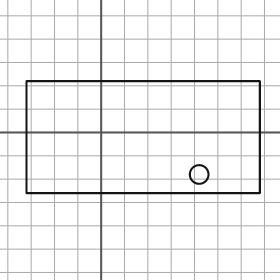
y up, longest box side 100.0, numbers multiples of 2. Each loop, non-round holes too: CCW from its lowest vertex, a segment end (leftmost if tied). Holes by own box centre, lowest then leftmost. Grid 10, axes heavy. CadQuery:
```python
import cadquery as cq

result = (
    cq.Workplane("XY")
    .moveTo(-32.0, -26.0)
    .lineTo(68.0, -26.0)
    .lineTo(68.0, 22.0)
    .lineTo(-32.0, 22.0)
    .close()
    .moveTo(42.0, -18.0)
    .circle(4.0)
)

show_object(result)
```